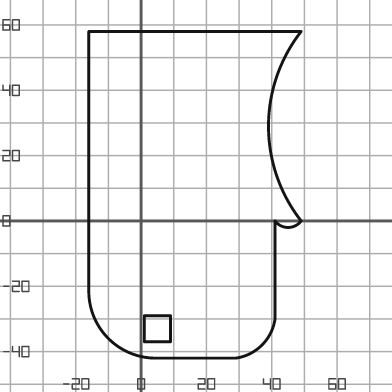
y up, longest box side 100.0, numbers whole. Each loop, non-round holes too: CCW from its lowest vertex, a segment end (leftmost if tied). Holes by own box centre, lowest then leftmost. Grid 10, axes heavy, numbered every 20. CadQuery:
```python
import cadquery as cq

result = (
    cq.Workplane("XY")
    .moveTo(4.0, -42.0)
    .lineTo(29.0, -42.0)
    .threePointArc((37.0, -38.0), (41.0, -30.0))
    .lineTo(41.0, 0.0)
    .threePointArc((45.0, -2.0), (49.0, 0.0))
    .threePointArc((39.0, 29.0), (49.0, 58.0))
    .lineTo(-16.0, 58.0)
    .lineTo(-16.0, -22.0)
    .threePointArc((-10.0, -36.0), (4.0, -42.0))
    .close()
    .moveTo(1.0, -37.0)
    .lineTo(9.0, -37.0)
    .lineTo(9.0, -29.0)
    .lineTo(1.0, -29.0)
    .close()
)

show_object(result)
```